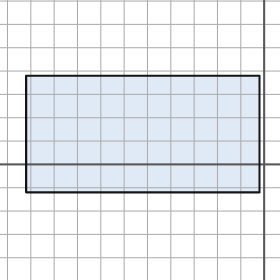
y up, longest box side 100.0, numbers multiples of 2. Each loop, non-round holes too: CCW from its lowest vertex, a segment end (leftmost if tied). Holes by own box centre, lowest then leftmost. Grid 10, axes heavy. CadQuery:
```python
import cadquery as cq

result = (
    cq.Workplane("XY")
    .moveTo(-102.0, -12.0)
    .lineTo(-2.0, -12.0)
    .lineTo(-2.0, 38.0)
    .lineTo(-102.0, 38.0)
    .close()
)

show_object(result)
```